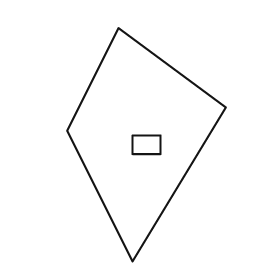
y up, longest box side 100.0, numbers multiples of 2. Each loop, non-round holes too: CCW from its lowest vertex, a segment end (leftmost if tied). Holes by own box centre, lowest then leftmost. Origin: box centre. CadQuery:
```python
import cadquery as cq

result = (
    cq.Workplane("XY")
    .moveTo(-6.0, -50.0)
    .lineTo(34.0, 16.0)
    .lineTo(-12.0, 50.0)
    .lineTo(-34.0, 6.0)
    .close()
    .moveTo(-6.0, -4.0)
    .lineTo(6.0, -4.0)
    .lineTo(6.0, 4.0)
    .lineTo(-6.0, 4.0)
    .close()
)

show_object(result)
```